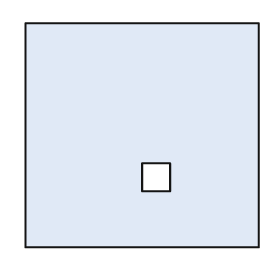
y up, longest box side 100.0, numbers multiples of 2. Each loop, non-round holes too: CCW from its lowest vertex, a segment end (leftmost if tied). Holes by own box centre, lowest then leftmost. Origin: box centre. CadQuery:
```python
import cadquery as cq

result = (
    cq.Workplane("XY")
    .moveTo(-50.0, -48.0)
    .lineTo(50.0, -48.0)
    .lineTo(50.0, 48.0)
    .lineTo(-50.0, 48.0)
    .close()
    .moveTo(0.0, -24.0)
    .lineTo(12.0, -24.0)
    .lineTo(12.0, -12.0)
    .lineTo(0.0, -12.0)
    .close()
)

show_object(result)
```